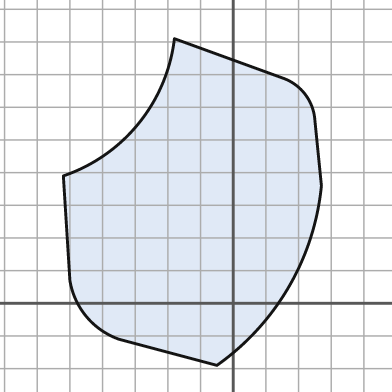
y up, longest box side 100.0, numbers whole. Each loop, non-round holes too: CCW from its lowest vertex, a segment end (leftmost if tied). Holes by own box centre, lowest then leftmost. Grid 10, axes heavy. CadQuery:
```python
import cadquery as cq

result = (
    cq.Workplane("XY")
    .moveTo(-5.0, -19.0)
    .threePointArc((17.0, 5.0), (27.0, 36.0))
    .lineTo(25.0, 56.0)
    .threePointArc((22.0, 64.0), (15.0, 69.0))
    .lineTo(-18.0, 81.0)
    .threePointArc((-29.0, 55.0), (-52.0, 39.0))
    .lineTo(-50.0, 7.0)
    .threePointArc((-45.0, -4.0), (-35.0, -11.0))
    .close()
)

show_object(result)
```